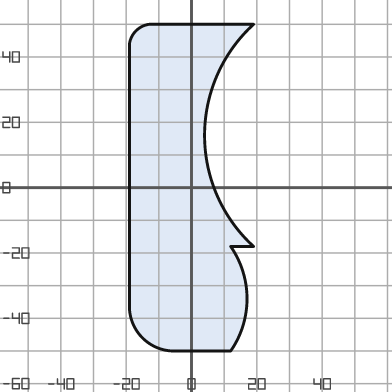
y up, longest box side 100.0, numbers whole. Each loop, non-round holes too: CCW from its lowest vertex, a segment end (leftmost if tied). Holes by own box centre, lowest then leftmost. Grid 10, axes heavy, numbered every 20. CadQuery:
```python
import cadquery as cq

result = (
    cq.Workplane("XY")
    .moveTo(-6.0, -50.0)
    .lineTo(12.0, -50.0)
    .threePointArc((17.0, -34.0), (12.0, -18.0))
    .lineTo(19.0, -18.0)
    .threePointArc((4.0, 16.0), (19.0, 50.0))
    .lineTo(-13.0, 50.0)
    .threePointArc((-17.0, 48.0), (-19.0, 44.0))
    .lineTo(-19.0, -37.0)
    .threePointArc((-15.0, -46.0), (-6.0, -50.0))
    .close()
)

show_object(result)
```